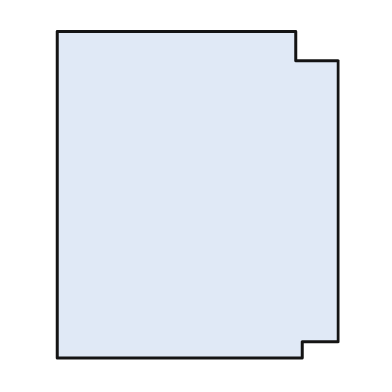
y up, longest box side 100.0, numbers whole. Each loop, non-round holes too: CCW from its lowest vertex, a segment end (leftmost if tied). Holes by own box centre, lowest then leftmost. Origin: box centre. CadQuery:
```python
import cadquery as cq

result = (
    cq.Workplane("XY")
    .moveTo(-43.0, -50.0)
    .lineTo(32.0, -50.0)
    .lineTo(32.0, -45.0)
    .lineTo(43.0, -45.0)
    .lineTo(43.0, 41.0)
    .lineTo(30.0, 41.0)
    .lineTo(30.0, 50.0)
    .lineTo(-43.0, 50.0)
    .close()
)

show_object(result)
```